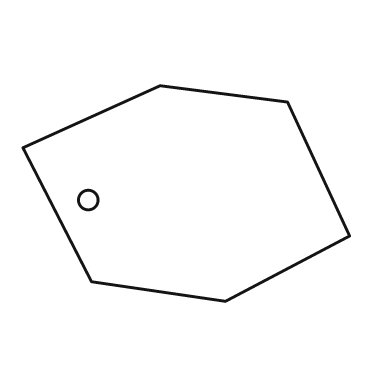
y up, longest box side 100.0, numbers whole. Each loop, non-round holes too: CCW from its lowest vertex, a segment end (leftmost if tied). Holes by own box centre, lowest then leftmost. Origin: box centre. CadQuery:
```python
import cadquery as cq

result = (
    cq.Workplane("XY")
    .moveTo(12.0, -33.0)
    .lineTo(50.0, -13.0)
    .lineTo(31.0, 28.0)
    .lineTo(-8.0, 33.0)
    .lineTo(-50.0, 14.0)
    .lineTo(-29.0, -27.0)
    .close()
    .moveTo(-30.0, -2.0)
    .circle(3.0)
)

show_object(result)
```